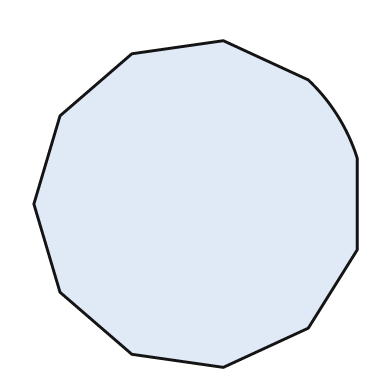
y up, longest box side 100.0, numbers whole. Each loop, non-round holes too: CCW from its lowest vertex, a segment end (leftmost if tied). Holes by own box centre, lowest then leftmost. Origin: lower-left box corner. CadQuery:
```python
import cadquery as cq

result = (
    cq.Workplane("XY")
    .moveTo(58.0, 0.0)
    .lineTo(84.0, 12.0)
    .lineTo(99.0, 36.0)
    .lineTo(99.0, 64.0)
    .threePointArc((93.0, 77.0), (84.0, 88.0))
    .lineTo(58.0, 100.0)
    .lineTo(30.0, 96.0)
    .lineTo(8.0, 77.0)
    .lineTo(0.0, 50.0)
    .lineTo(8.0, 23.0)
    .lineTo(30.0, 4.0)
    .close()
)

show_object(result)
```